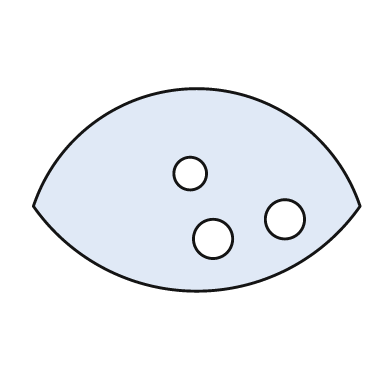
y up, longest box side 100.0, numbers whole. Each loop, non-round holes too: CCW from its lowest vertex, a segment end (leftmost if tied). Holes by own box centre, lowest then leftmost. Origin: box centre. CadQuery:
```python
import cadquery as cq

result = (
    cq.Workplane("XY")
    .moveTo(-50.0, -5.0)
    .threePointArc((0.0, -31.0), (50.0, -5.0))
    .threePointArc((0.0, 31.0), (-50.0, -5.0))
    .close()
    .moveTo(5.0, -15.0)
    .circle(6.0)
    .moveTo(27.0, -9.0)
    .circle(6.0)
    .moveTo(-2.0, 5.0)
    .circle(5.0)
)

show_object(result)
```